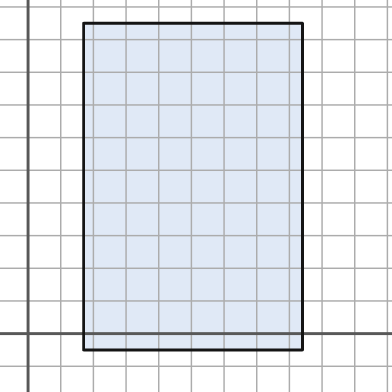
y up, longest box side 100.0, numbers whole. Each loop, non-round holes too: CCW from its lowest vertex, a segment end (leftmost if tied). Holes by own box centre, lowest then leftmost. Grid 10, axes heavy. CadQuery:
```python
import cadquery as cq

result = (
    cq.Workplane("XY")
    .moveTo(17.0, -5.0)
    .lineTo(84.0, -5.0)
    .lineTo(84.0, 95.0)
    .lineTo(17.0, 95.0)
    .close()
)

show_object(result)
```